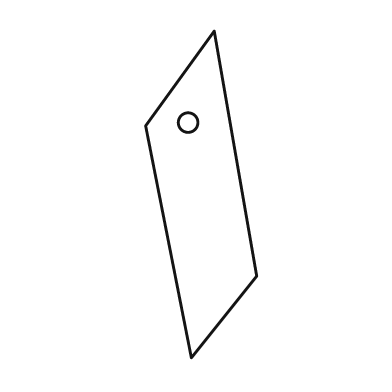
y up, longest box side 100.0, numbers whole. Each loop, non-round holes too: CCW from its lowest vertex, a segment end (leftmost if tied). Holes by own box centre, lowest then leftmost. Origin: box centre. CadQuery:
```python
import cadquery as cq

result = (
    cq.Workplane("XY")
    .moveTo(-3.0, -50.0)
    .lineTo(17.0, -25.0)
    .lineTo(4.0, 50.0)
    .lineTo(-17.0, 21.0)
    .close()
    .moveTo(-4.0, 22.0)
    .circle(3.0)
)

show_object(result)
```